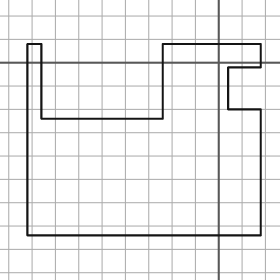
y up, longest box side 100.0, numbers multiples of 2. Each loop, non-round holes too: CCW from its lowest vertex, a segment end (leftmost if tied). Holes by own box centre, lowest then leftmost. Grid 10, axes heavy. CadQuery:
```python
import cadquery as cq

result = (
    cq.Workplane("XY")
    .moveTo(-82.0, -74.0)
    .lineTo(18.0, -74.0)
    .lineTo(18.0, -20.0)
    .lineTo(4.0, -20.0)
    .lineTo(4.0, -2.0)
    .lineTo(18.0, -2.0)
    .lineTo(18.0, 8.0)
    .lineTo(-24.0, 8.0)
    .lineTo(-24.0, -24.0)
    .lineTo(-76.0, -24.0)
    .lineTo(-76.0, 8.0)
    .lineTo(-82.0, 8.0)
    .close()
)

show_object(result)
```